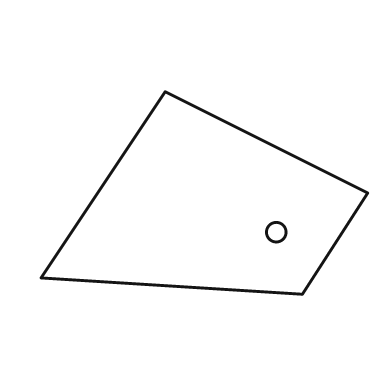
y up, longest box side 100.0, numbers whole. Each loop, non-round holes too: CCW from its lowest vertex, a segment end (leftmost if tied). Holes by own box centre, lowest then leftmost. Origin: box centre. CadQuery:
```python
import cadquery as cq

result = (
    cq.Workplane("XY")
    .moveTo(30.0, -31.0)
    .lineTo(50.0, 0.0)
    .lineTo(-12.0, 31.0)
    .lineTo(-50.0, -26.0)
    .close()
    .moveTo(22.0, -12.0)
    .circle(3.0)
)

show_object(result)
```